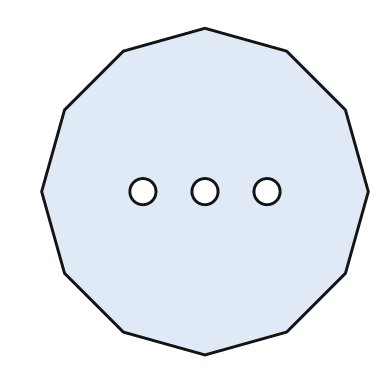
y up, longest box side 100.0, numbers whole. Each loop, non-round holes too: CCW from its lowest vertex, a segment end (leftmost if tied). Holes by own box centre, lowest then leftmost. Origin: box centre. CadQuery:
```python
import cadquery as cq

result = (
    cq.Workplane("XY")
    .moveTo(0.0, -50.0)
    .lineTo(25.0, -43.0)
    .lineTo(43.0, -25.0)
    .lineTo(50.0, 0.0)
    .lineTo(43.0, 25.0)
    .lineTo(25.0, 43.0)
    .lineTo(0.0, 50.0)
    .lineTo(-25.0, 43.0)
    .lineTo(-43.0, 25.0)
    .lineTo(-50.0, 0.0)
    .lineTo(-43.0, -25.0)
    .lineTo(-25.0, -43.0)
    .close()
    .moveTo(-19.0, 0.0)
    .circle(4.0)
    .moveTo(0.0, 0.0)
    .circle(4.0)
    .moveTo(19.0, 0.0)
    .circle(4.0)
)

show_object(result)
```